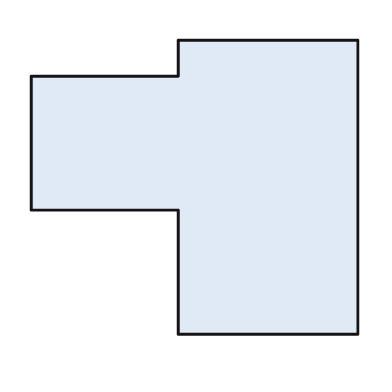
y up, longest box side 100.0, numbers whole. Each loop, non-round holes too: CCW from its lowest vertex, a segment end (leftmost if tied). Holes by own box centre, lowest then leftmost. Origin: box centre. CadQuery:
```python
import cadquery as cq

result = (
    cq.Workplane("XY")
    .moveTo(-5.0, -45.0)
    .lineTo(50.0, -45.0)
    .lineTo(50.0, 45.0)
    .lineTo(-5.0, 45.0)
    .lineTo(-5.0, 34.0)
    .lineTo(-50.0, 34.0)
    .lineTo(-50.0, -7.0)
    .lineTo(-5.0, -7.0)
    .close()
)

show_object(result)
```